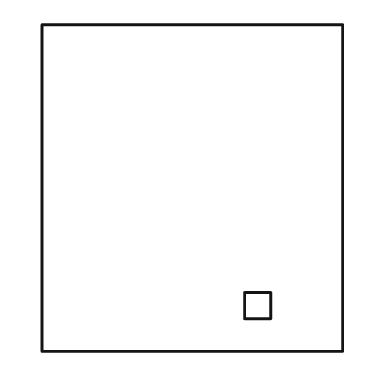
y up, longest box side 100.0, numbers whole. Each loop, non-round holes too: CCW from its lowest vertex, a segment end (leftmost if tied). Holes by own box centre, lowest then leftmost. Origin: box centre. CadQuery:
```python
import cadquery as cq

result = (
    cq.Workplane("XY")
    .moveTo(-46.0, -50.0)
    .lineTo(46.0, -50.0)
    .lineTo(46.0, 50.0)
    .lineTo(-46.0, 50.0)
    .close()
    .moveTo(16.0, -40.0)
    .lineTo(24.0, -40.0)
    .lineTo(24.0, -32.0)
    .lineTo(16.0, -32.0)
    .close()
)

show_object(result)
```